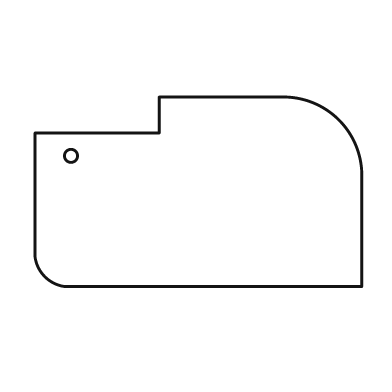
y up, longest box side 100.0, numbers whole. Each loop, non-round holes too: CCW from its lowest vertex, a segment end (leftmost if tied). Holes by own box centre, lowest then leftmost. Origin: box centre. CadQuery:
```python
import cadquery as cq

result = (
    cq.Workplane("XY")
    .moveTo(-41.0, -29.0)
    .lineTo(50.0, -29.0)
    .lineTo(50.0, 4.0)
    .threePointArc((43.0, 22.0), (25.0, 29.0))
    .lineTo(-12.0, 29.0)
    .lineTo(-12.0, 18.0)
    .lineTo(-50.0, 18.0)
    .lineTo(-50.0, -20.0)
    .threePointArc((-47.0, -26.0), (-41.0, -29.0))
    .close()
    .moveTo(-39.0, 11.0)
    .circle(2.0)
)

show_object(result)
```